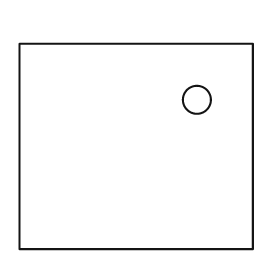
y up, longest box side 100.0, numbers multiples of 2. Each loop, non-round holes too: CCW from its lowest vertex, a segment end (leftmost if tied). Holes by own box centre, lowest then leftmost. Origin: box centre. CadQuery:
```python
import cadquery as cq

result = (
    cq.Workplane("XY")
    .moveTo(-50.0, -44.0)
    .lineTo(50.0, -44.0)
    .lineTo(50.0, 44.0)
    .lineTo(-50.0, 44.0)
    .close()
    .moveTo(26.0, 20.0)
    .circle(6.0)
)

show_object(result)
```